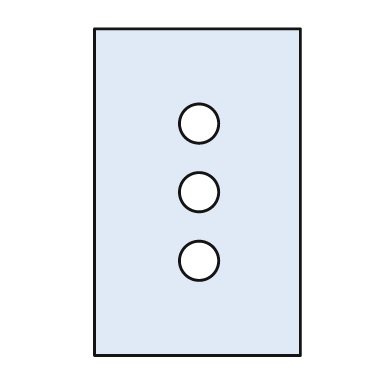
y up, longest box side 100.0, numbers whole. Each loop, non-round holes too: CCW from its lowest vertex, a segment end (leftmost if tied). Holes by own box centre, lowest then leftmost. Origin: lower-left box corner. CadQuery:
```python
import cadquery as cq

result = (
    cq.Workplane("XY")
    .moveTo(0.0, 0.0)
    .lineTo(63.0, 0.0)
    .lineTo(63.0, 100.0)
    .lineTo(0.0, 100.0)
    .close()
    .moveTo(32.0, 29.0)
    .circle(6.0)
    .moveTo(32.0, 50.0)
    .circle(6.0)
    .moveTo(32.0, 71.0)
    .circle(6.0)
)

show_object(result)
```